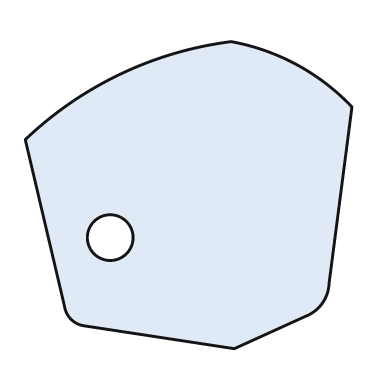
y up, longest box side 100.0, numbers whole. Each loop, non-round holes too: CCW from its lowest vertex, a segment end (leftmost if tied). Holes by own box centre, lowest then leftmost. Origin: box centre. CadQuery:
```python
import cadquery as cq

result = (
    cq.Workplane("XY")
    .moveTo(14.0, -47.0)
    .lineTo(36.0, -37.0)
    .threePointArc((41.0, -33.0), (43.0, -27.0))
    .lineTo(50.0, 27.0)
    .threePointArc((33.0, 40.0), (13.0, 47.0))
    .threePointArc((-21.0, 37.0), (-50.0, 17.0))
    .lineTo(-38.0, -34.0)
    .threePointArc((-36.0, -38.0), (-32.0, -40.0))
    .close()
    .moveTo(-24.0, -13.0)
    .circle(7.0)
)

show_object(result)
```